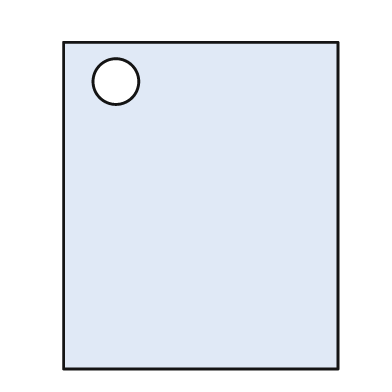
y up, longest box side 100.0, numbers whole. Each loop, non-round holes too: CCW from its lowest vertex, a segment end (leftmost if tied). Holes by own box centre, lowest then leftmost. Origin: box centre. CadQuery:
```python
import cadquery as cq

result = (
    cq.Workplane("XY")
    .moveTo(-42.0, -50.0)
    .lineTo(42.0, -50.0)
    .lineTo(42.0, 50.0)
    .lineTo(-42.0, 50.0)
    .close()
    .moveTo(-26.0, 38.0)
    .circle(7.0)
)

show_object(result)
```